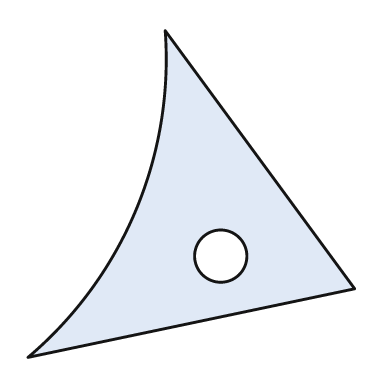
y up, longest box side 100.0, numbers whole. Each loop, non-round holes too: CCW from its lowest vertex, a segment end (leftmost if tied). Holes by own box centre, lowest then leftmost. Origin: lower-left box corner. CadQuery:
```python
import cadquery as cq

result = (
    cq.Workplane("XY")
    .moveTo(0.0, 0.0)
    .lineTo(100.0, 21.0)
    .lineTo(42.0, 100.0)
    .threePointArc((33.0, 45.0), (0.0, 0.0))
    .close()
    .moveTo(59.0, 31.0)
    .circle(8.0)
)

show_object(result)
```